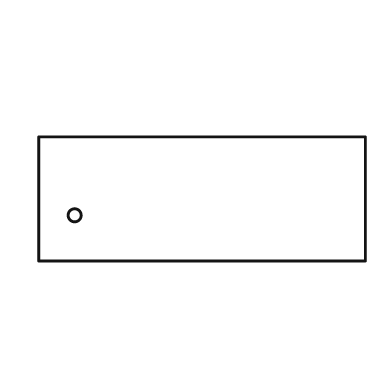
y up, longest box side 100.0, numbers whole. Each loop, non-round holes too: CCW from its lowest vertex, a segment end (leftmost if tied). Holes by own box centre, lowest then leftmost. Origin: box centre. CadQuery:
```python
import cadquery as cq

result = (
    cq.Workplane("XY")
    .moveTo(-50.0, -19.0)
    .lineTo(50.0, -19.0)
    .lineTo(50.0, 19.0)
    .lineTo(-50.0, 19.0)
    .close()
    .moveTo(-39.0, -5.0)
    .circle(2.0)
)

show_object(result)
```